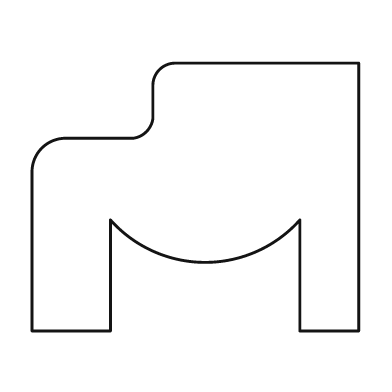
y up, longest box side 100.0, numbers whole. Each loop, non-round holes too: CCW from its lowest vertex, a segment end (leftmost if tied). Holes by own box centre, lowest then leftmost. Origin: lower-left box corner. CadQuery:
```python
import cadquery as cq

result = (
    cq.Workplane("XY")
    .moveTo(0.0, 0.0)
    .lineTo(24.0, 0.0)
    .lineTo(24.0, 34.0)
    .threePointArc((53.0, 21.0), (82.0, 34.0))
    .lineTo(82.0, 0.0)
    .lineTo(100.0, 0.0)
    .lineTo(100.0, 82.0)
    .lineTo(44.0, 82.0)
    .threePointArc((39.0, 80.0), (37.0, 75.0))
    .lineTo(37.0, 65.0)
    .threePointArc((35.0, 61.0), (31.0, 59.0))
    .lineTo(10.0, 59.0)
    .threePointArc((3.0, 56.0), (0.0, 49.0))
    .close()
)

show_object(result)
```